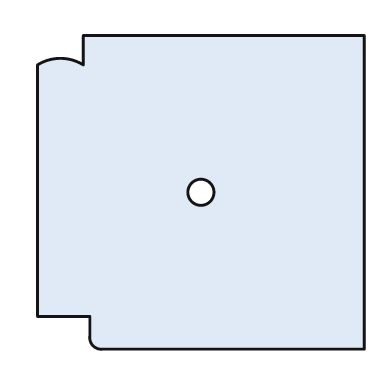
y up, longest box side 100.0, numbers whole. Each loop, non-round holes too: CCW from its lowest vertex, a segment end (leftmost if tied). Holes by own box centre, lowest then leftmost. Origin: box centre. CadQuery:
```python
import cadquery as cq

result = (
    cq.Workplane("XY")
    .moveTo(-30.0, -48.0)
    .lineTo(50.0, -48.0)
    .lineTo(50.0, 48.0)
    .lineTo(-36.0, 48.0)
    .lineTo(-36.0, 39.0)
    .threePointArc((-43.0, 41.0), (-50.0, 39.0))
    .lineTo(-50.0, -38.0)
    .lineTo(-34.0, -38.0)
    .lineTo(-34.0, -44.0)
    .threePointArc((-33.0, -47.0), (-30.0, -48.0))
    .close()
    .moveTo(0.0, 0.0)
    .circle(4.0)
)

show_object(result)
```